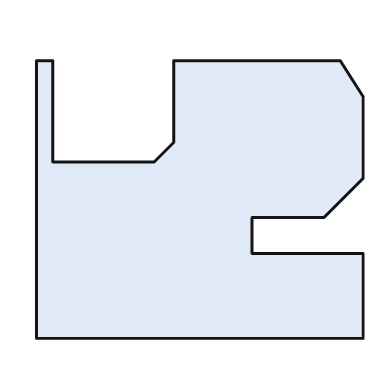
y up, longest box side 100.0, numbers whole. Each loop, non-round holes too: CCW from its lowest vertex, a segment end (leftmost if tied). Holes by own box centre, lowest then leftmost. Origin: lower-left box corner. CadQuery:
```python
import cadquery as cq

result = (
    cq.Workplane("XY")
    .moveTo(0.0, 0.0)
    .lineTo(100.0, 0.0)
    .lineTo(100.0, 26.0)
    .lineTo(66.0, 26.0)
    .lineTo(66.0, 37.0)
    .lineTo(88.0, 37.0)
    .lineTo(100.0, 49.0)
    .lineTo(100.0, 74.0)
    .lineTo(93.0, 85.0)
    .lineTo(42.0, 85.0)
    .lineTo(42.0, 60.0)
    .lineTo(36.0, 54.0)
    .lineTo(5.0, 54.0)
    .lineTo(5.0, 85.0)
    .lineTo(0.0, 85.0)
    .close()
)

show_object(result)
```